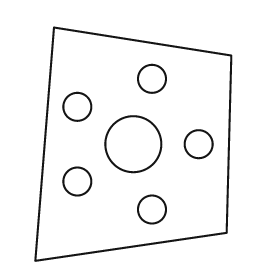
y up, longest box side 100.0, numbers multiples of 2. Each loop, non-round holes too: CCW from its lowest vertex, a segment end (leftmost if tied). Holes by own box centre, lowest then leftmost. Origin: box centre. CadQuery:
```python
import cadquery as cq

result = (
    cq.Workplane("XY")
    .moveTo(-42.0, -50.0)
    .lineTo(40.0, -38.0)
    .lineTo(42.0, 38.0)
    .lineTo(-34.0, 50.0)
    .close()
    .moveTo(8.0, -28.0)
    .circle(6.0)
    .moveTo(-24.0, -16.0)
    .circle(6.0)
    .moveTo(0.0, 0.0)
    .circle(12.0)
    .moveTo(28.0, 0.0)
    .circle(6.0)
    .moveTo(-24.0, 16.0)
    .circle(6.0)
    .moveTo(8.0, 28.0)
    .circle(6.0)
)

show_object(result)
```